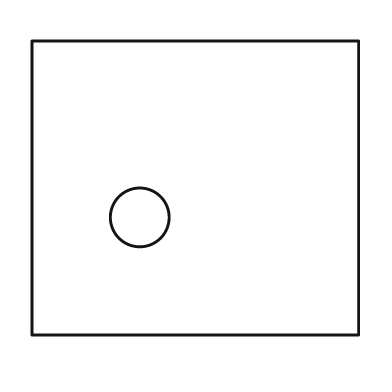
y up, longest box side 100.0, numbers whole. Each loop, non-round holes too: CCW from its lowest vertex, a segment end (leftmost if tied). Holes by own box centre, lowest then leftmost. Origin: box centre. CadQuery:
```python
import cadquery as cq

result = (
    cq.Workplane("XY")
    .moveTo(-50.0, -45.0)
    .lineTo(50.0, -45.0)
    .lineTo(50.0, 45.0)
    .lineTo(-50.0, 45.0)
    .close()
    .moveTo(-17.0, -9.0)
    .circle(9.0)
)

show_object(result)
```